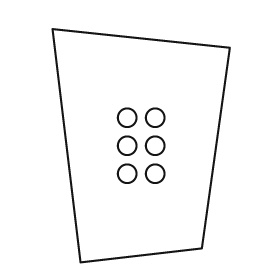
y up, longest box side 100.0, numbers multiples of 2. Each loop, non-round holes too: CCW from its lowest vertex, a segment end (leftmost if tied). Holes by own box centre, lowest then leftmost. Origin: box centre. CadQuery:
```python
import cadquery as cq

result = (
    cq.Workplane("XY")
    .moveTo(-26.0, -50.0)
    .lineTo(26.0, -44.0)
    .lineTo(38.0, 42.0)
    .lineTo(-38.0, 50.0)
    .close()
    .moveTo(-6.0, -12.0)
    .circle(4.0)
    .moveTo(6.0, -12.0)
    .circle(4.0)
    .moveTo(-6.0, 0.0)
    .circle(4.0)
    .moveTo(6.0, 0.0)
    .circle(4.0)
    .moveTo(-6.0, 12.0)
    .circle(4.0)
    .moveTo(6.0, 12.0)
    .circle(4.0)
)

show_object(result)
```